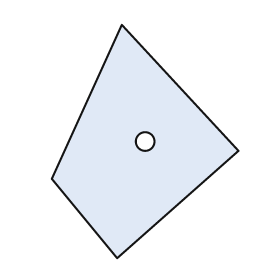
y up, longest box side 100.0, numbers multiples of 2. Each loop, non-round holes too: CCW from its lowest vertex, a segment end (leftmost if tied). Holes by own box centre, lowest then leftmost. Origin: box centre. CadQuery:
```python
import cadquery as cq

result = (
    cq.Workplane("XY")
    .moveTo(-12.0, -50.0)
    .lineTo(40.0, -4.0)
    .lineTo(-10.0, 50.0)
    .lineTo(-40.0, -16.0)
    .close()
    .moveTo(0.0, 0.0)
    .circle(4.0)
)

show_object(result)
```